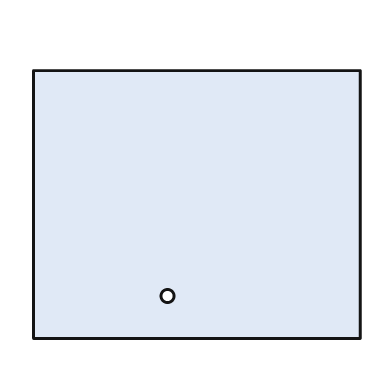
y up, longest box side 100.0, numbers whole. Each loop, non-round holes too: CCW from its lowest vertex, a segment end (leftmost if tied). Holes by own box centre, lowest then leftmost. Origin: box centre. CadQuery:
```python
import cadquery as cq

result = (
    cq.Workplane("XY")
    .moveTo(-50.0, -41.0)
    .lineTo(50.0, -41.0)
    .lineTo(50.0, 41.0)
    .lineTo(-50.0, 41.0)
    .close()
    .moveTo(-9.0, -28.0)
    .circle(2.0)
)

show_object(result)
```